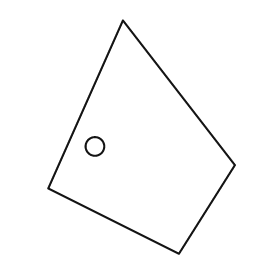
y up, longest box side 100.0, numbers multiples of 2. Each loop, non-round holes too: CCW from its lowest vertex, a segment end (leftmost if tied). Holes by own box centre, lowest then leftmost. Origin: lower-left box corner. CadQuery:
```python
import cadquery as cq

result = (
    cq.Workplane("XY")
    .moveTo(56.0, 0.0)
    .lineTo(80.0, 38.0)
    .lineTo(32.0, 100.0)
    .lineTo(0.0, 28.0)
    .close()
    .moveTo(20.0, 46.0)
    .circle(4.0)
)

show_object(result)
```